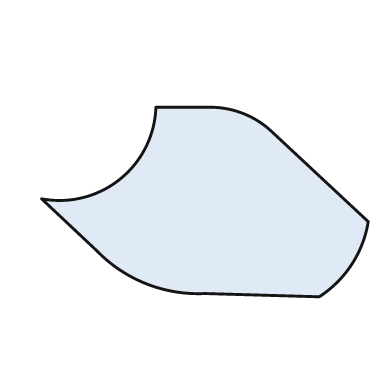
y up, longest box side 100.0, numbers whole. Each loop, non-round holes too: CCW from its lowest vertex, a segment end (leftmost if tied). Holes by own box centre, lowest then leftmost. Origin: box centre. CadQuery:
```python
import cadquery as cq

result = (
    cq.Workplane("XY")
    .moveTo(35.0, -29.0)
    .threePointArc((45.0, -19.0), (50.0, -6.0))
    .lineTo(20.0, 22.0)
    .threePointArc((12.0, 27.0), (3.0, 29.0))
    .lineTo(-15.0, 29.0)
    .threePointArc((-26.0, 7.0), (-50.0, 1.0))
    .lineTo(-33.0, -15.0)
    .threePointArc((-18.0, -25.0), (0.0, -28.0))
    .close()
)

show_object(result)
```